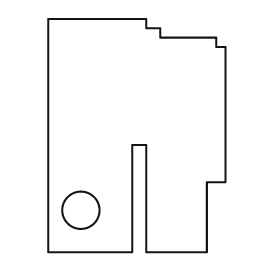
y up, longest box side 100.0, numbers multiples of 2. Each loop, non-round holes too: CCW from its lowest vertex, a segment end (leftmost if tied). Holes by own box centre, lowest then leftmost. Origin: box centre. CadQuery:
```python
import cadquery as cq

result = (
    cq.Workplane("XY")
    .moveTo(-38.0, -50.0)
    .lineTo(-2.0, -50.0)
    .lineTo(-2.0, -4.0)
    .lineTo(4.0, -4.0)
    .lineTo(4.0, -50.0)
    .lineTo(30.0, -50.0)
    .lineTo(30.0, -20.0)
    .lineTo(38.0, -20.0)
    .lineTo(38.0, 38.0)
    .lineTo(34.0, 38.0)
    .lineTo(34.0, 42.0)
    .lineTo(10.0, 42.0)
    .lineTo(10.0, 46.0)
    .lineTo(4.0, 46.0)
    .lineTo(4.0, 50.0)
    .lineTo(-38.0, 50.0)
    .close()
    .moveTo(-24.0, -32.0)
    .circle(8.0)
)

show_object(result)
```